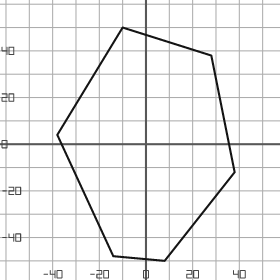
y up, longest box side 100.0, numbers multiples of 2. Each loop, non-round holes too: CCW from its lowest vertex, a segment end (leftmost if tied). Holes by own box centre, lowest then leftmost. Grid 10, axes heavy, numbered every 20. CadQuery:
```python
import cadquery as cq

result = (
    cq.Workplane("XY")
    .moveTo(8.0, -50.0)
    .lineTo(38.0, -12.0)
    .lineTo(28.0, 38.0)
    .lineTo(-10.0, 50.0)
    .lineTo(-38.0, 4.0)
    .lineTo(-14.0, -48.0)
    .close()
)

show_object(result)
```